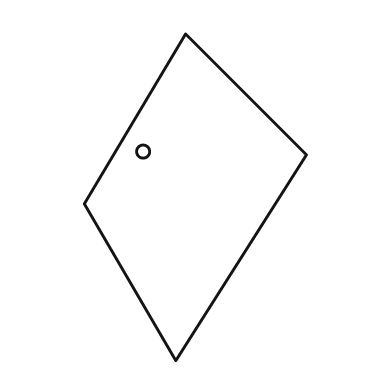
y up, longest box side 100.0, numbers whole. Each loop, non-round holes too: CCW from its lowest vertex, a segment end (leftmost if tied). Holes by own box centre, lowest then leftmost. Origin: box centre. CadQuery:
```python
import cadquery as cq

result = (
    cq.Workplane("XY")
    .moveTo(-6.0, -50.0)
    .lineTo(34.0, 13.0)
    .lineTo(-3.0, 50.0)
    .lineTo(-34.0, -2.0)
    .close()
    .moveTo(-16.0, 14.0)
    .circle(2.0)
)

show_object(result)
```